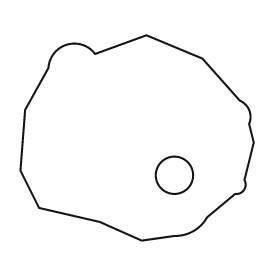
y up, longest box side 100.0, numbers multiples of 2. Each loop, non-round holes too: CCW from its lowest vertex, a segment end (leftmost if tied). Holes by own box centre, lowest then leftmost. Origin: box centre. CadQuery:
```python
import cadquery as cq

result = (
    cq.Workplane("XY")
    .moveTo(2.0, -44.0)
    .lineTo(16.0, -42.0)
    .threePointArc((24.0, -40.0), (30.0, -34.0))
    .lineTo(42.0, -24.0)
    .threePointArc((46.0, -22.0), (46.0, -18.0))
    .lineTo(50.0, -2.0)
    .lineTo(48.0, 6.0)
    .threePointArc((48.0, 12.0), (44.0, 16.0))
    .lineTo(28.0, 34.0)
    .lineTo(4.0, 44.0)
    .lineTo(-18.0, 36.0)
    .threePointArc((-30.0, 40.0), (-38.0, 30.0))
    .lineTo(-48.0, 12.0)
    .lineTo(-50.0, -14.0)
    .lineTo(-42.0, -30.0)
    .lineTo(-16.0, -36.0)
    .close()
    .moveTo(16.0, -16.0)
    .circle(8.0)
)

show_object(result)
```